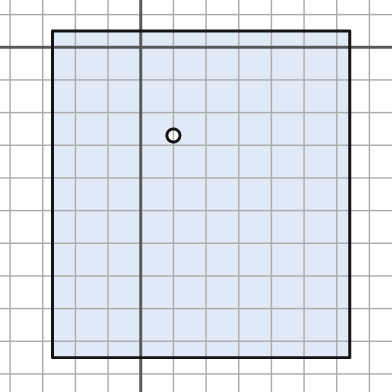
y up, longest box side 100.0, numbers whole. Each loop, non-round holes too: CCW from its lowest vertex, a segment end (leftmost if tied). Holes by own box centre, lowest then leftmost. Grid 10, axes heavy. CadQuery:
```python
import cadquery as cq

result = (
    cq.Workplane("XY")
    .moveTo(-27.0, -95.0)
    .lineTo(64.0, -95.0)
    .lineTo(64.0, 5.0)
    .lineTo(-27.0, 5.0)
    .close()
    .moveTo(10.0, -27.0)
    .circle(2.0)
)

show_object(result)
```